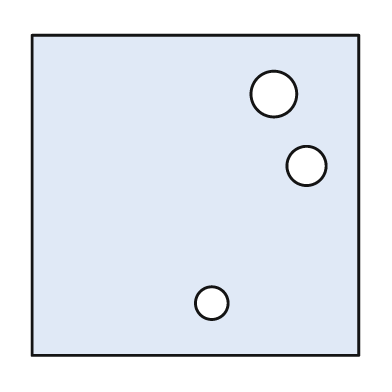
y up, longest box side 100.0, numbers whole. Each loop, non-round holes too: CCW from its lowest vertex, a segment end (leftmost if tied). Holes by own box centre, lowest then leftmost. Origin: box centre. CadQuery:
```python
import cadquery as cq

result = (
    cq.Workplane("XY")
    .moveTo(-50.0, -49.0)
    .lineTo(50.0, -49.0)
    .lineTo(50.0, 49.0)
    .lineTo(-50.0, 49.0)
    .close()
    .moveTo(5.0, -33.0)
    .circle(5.0)
    .moveTo(34.0, 9.0)
    .circle(6.0)
    .moveTo(24.0, 31.0)
    .circle(7.0)
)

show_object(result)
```